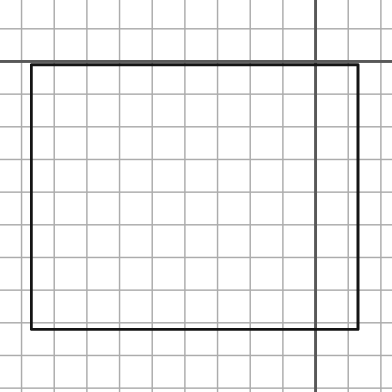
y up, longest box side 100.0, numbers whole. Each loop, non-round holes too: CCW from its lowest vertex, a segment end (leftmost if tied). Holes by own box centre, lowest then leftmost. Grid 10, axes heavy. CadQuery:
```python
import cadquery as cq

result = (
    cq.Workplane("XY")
    .moveTo(-87.0, -82.0)
    .lineTo(13.0, -82.0)
    .lineTo(13.0, -1.0)
    .lineTo(-87.0, -1.0)
    .close()
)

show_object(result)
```